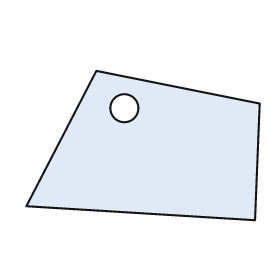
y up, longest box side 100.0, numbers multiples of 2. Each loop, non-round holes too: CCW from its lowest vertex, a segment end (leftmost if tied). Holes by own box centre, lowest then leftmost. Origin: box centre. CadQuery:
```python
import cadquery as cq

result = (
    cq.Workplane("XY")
    .moveTo(48.0, -32.0)
    .lineTo(50.0, 18.0)
    .lineTo(-20.0, 32.0)
    .lineTo(-50.0, -26.0)
    .close()
    .moveTo(-8.0, 16.0)
    .circle(6.0)
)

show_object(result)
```